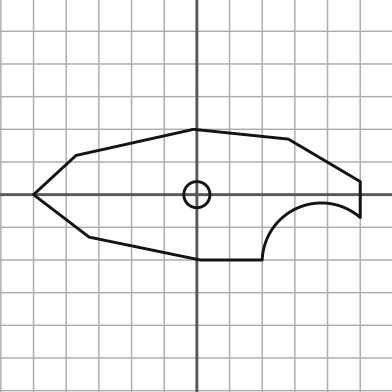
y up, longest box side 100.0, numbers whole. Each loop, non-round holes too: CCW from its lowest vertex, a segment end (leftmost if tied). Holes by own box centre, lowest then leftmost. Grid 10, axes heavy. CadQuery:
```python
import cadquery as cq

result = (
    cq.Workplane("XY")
    .moveTo(1.0, -20.0)
    .lineTo(20.0, -20.0)
    .threePointArc((31.0, -4.0), (50.0, -7.0))
    .lineTo(50.0, 4.0)
    .lineTo(28.0, 17.0)
    .lineTo(-1.0, 20.0)
    .lineTo(-37.0, 12.0)
    .lineTo(-50.0, 0.0)
    .lineTo(-33.0, -13.0)
    .close()
    .moveTo(0.0, 0.0)
    .circle(4.0)
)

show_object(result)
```